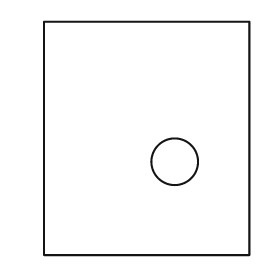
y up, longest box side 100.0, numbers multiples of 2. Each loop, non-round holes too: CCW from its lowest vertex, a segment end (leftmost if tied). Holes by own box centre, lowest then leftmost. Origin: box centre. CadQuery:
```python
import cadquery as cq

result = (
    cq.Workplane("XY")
    .moveTo(-44.0, -50.0)
    .lineTo(44.0, -50.0)
    .lineTo(44.0, 50.0)
    .lineTo(-44.0, 50.0)
    .close()
    .moveTo(12.0, -10.0)
    .circle(10.0)
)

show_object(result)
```